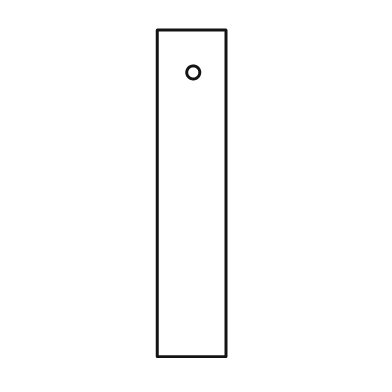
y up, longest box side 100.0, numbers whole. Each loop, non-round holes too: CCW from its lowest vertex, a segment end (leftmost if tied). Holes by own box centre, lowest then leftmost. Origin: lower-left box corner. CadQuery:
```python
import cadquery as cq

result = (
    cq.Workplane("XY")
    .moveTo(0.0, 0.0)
    .lineTo(21.0, 0.0)
    .lineTo(21.0, 100.0)
    .lineTo(0.0, 100.0)
    .close()
    .moveTo(11.0, 87.0)
    .circle(2.0)
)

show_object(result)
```